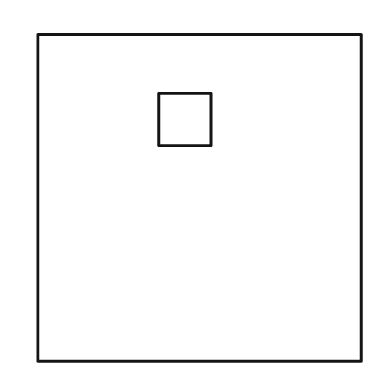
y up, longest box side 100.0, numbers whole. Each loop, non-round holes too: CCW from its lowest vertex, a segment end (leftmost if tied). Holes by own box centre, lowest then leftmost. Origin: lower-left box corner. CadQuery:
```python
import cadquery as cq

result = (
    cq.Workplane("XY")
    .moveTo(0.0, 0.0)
    .lineTo(99.0, 0.0)
    .lineTo(99.0, 100.0)
    .lineTo(0.0, 100.0)
    .close()
    .moveTo(37.0, 66.0)
    .lineTo(53.0, 66.0)
    .lineTo(53.0, 82.0)
    .lineTo(37.0, 82.0)
    .close()
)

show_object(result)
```